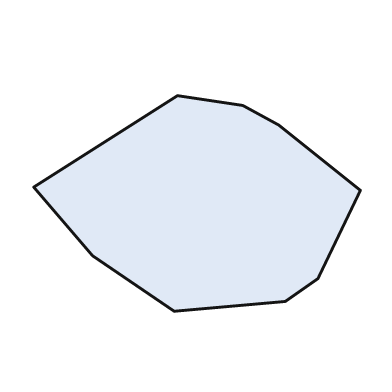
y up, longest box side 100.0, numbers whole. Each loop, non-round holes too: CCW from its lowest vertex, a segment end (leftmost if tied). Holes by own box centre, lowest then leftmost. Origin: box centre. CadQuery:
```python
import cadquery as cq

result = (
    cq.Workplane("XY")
    .moveTo(-7.0, -33.0)
    .lineTo(27.0, -30.0)
    .lineTo(37.0, -23.0)
    .lineTo(50.0, 4.0)
    .lineTo(25.0, 24.0)
    .lineTo(14.0, 30.0)
    .lineTo(-6.0, 33.0)
    .lineTo(-50.0, 5.0)
    .lineTo(-32.0, -16.0)
    .close()
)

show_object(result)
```